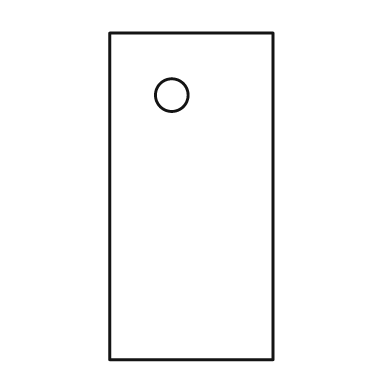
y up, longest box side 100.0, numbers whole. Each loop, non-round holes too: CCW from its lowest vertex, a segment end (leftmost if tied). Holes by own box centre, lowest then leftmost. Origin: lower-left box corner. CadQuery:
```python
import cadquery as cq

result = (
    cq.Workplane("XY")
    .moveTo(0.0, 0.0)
    .lineTo(50.0, 0.0)
    .lineTo(50.0, 100.0)
    .lineTo(0.0, 100.0)
    .close()
    .moveTo(19.0, 81.0)
    .circle(5.0)
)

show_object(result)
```